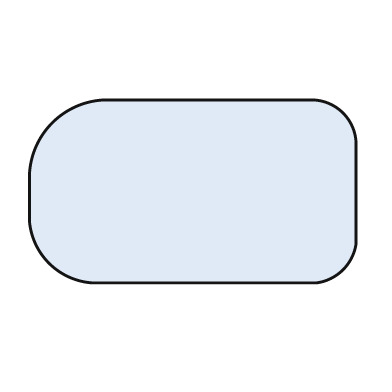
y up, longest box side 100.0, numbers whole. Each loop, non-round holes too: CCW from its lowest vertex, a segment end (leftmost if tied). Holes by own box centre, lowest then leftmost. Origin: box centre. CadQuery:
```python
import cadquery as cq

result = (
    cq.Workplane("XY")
    .moveTo(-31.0, -28.0)
    .lineTo(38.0, -28.0)
    .threePointArc((46.0, -24.0), (50.0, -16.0))
    .lineTo(50.0, 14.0)
    .threePointArc((46.0, 24.0), (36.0, 28.0))
    .lineTo(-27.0, 28.0)
    .threePointArc((-43.0, 21.0), (-50.0, 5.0))
    .lineTo(-50.0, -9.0)
    .threePointArc((-44.0, -22.0), (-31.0, -28.0))
    .close()
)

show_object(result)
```